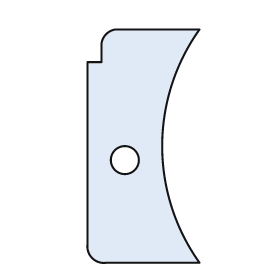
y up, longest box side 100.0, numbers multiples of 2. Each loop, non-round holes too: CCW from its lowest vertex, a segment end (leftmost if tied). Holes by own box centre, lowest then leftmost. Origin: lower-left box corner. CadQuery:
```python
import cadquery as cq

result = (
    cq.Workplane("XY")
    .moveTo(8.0, 0.0)
    .lineTo(48.0, 0.0)
    .threePointArc((32.0, 50.0), (48.0, 100.0))
    .lineTo(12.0, 100.0)
    .threePointArc((8.0, 98.0), (6.0, 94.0))
    .lineTo(6.0, 86.0)
    .lineTo(0.0, 86.0)
    .lineTo(0.0, 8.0)
    .threePointArc((2.0, 2.0), (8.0, 0.0))
    .close()
    .moveTo(16.0, 44.0)
    .circle(6.0)
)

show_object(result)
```